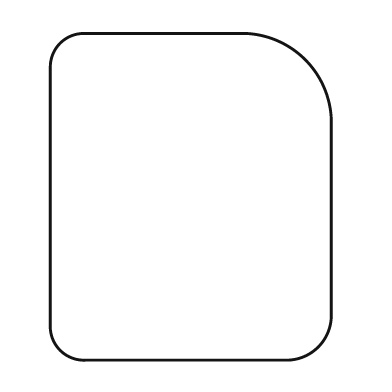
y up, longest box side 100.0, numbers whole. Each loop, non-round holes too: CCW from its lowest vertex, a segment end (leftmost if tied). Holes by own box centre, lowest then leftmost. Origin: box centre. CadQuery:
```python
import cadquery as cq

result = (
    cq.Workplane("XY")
    .moveTo(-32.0, -50.0)
    .lineTo(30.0, -50.0)
    .threePointArc((39.0, -46.0), (43.0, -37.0))
    .lineTo(43.0, 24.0)
    .threePointArc((35.0, 42.0), (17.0, 50.0))
    .lineTo(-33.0, 50.0)
    .threePointArc((-40.0, 47.0), (-43.0, 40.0))
    .lineTo(-43.0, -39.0)
    .threePointArc((-40.0, -47.0), (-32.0, -50.0))
    .close()
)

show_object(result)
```